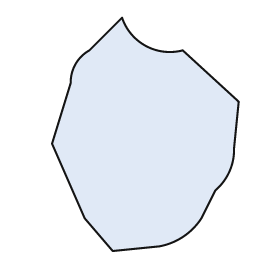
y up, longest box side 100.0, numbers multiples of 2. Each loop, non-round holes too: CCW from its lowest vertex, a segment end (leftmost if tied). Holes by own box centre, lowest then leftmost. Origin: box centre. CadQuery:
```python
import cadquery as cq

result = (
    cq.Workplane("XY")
    .moveTo(-14.0, -50.0)
    .lineTo(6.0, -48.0)
    .threePointArc((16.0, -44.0), (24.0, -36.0))
    .lineTo(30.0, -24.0)
    .threePointArc((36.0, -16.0), (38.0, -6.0))
    .lineTo(40.0, 14.0)
    .lineTo(16.0, 36.0)
    .threePointArc((0.0, 38.0), (-10.0, 50.0))
    .lineTo(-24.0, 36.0)
    .threePointArc((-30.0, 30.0), (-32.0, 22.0))
    .lineTo(-40.0, -4.0)
    .lineTo(-26.0, -36.0)
    .close()
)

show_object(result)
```